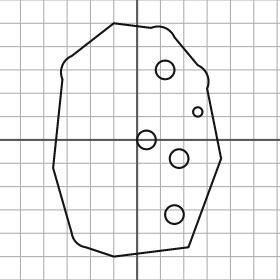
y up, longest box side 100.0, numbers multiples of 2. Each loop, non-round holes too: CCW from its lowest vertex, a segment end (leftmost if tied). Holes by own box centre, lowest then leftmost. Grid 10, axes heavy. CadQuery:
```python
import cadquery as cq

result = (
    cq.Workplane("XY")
    .moveTo(-10.0, -50.0)
    .lineTo(22.0, -46.0)
    .lineTo(36.0, -8.0)
    .lineTo(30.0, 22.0)
    .threePointArc((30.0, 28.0), (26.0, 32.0))
    .lineTo(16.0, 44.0)
    .threePointArc((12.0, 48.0), (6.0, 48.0))
    .lineTo(-10.0, 50.0)
    .lineTo(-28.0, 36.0)
    .threePointArc((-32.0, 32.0), (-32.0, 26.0))
    .lineTo(-36.0, -12.0)
    .lineTo(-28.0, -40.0)
    .threePointArc((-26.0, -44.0), (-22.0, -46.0))
    .close()
    .moveTo(16.0, -32.0)
    .circle(4.0)
    .moveTo(18.0, -8.0)
    .circle(4.0)
    .moveTo(4.0, 0.0)
    .circle(4.0)
    .moveTo(26.0, 12.0)
    .circle(2.0)
    .moveTo(12.0, 30.0)
    .circle(4.0)
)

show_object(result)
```